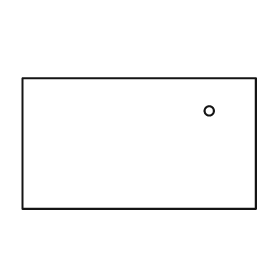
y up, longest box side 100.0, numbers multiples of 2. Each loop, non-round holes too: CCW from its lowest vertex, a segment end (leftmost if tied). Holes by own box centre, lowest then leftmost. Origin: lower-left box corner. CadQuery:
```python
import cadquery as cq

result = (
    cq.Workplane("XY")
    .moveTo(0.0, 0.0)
    .lineTo(100.0, 0.0)
    .lineTo(100.0, 56.0)
    .lineTo(0.0, 56.0)
    .close()
    .moveTo(80.0, 42.0)
    .circle(2.0)
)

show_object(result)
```